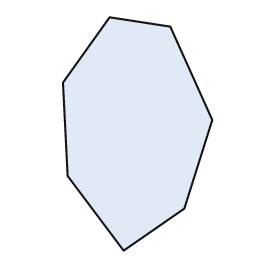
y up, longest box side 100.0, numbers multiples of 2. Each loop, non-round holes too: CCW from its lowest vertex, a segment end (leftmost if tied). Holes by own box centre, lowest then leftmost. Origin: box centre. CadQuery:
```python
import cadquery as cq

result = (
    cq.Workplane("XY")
    .moveTo(-6.0, -50.0)
    .lineTo(20.0, -32.0)
    .lineTo(32.0, 6.0)
    .lineTo(14.0, 46.0)
    .lineTo(-12.0, 50.0)
    .lineTo(-32.0, 22.0)
    .lineTo(-30.0, -18.0)
    .close()
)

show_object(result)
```